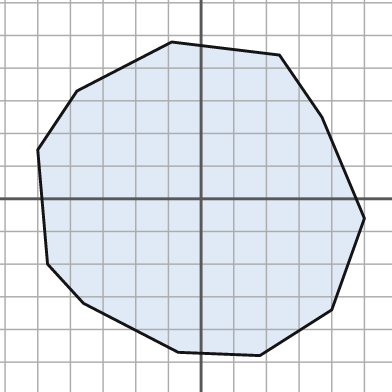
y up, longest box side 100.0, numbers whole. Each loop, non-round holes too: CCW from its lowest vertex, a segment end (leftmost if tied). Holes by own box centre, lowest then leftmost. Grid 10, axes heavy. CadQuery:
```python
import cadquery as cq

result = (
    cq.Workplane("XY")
    .moveTo(18.0, -48.0)
    .lineTo(40.0, -34.0)
    .lineTo(50.0, -6.0)
    .lineTo(37.0, 25.0)
    .lineTo(24.0, 44.0)
    .lineTo(-9.0, 48.0)
    .lineTo(-38.0, 33.0)
    .lineTo(-50.0, 15.0)
    .lineTo(-47.0, -20.0)
    .lineTo(-36.0, -32.0)
    .lineTo(-7.0, -47.0)
    .close()
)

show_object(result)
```